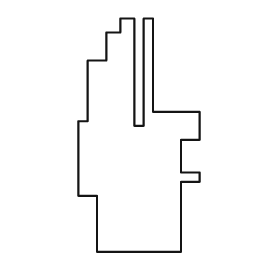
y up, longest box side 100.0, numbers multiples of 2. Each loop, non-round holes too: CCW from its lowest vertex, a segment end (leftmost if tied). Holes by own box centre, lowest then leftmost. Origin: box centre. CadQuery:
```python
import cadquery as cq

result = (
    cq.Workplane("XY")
    .moveTo(-18.0, -50.0)
    .lineTo(18.0, -50.0)
    .lineTo(18.0, -20.0)
    .lineTo(26.0, -20.0)
    .lineTo(26.0, -16.0)
    .lineTo(18.0, -16.0)
    .lineTo(18.0, -2.0)
    .lineTo(26.0, -2.0)
    .lineTo(26.0, 10.0)
    .lineTo(6.0, 10.0)
    .lineTo(6.0, 50.0)
    .lineTo(2.0, 50.0)
    .lineTo(2.0, 4.0)
    .lineTo(-2.0, 4.0)
    .lineTo(-2.0, 50.0)
    .lineTo(-8.0, 50.0)
    .lineTo(-8.0, 44.0)
    .lineTo(-14.0, 44.0)
    .lineTo(-14.0, 32.0)
    .lineTo(-22.0, 32.0)
    .lineTo(-22.0, 6.0)
    .lineTo(-26.0, 6.0)
    .lineTo(-26.0, -26.0)
    .lineTo(-18.0, -26.0)
    .close()
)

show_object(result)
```